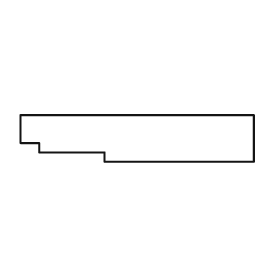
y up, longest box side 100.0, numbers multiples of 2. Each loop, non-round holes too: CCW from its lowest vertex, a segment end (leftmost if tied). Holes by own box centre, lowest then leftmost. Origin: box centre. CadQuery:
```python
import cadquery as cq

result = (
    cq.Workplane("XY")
    .moveTo(-14.0, -10.0)
    .lineTo(50.0, -10.0)
    .lineTo(50.0, 10.0)
    .lineTo(-50.0, 10.0)
    .lineTo(-50.0, -2.0)
    .lineTo(-42.0, -2.0)
    .lineTo(-42.0, -6.0)
    .lineTo(-14.0, -6.0)
    .close()
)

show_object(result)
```